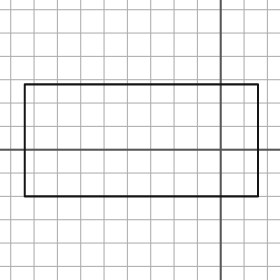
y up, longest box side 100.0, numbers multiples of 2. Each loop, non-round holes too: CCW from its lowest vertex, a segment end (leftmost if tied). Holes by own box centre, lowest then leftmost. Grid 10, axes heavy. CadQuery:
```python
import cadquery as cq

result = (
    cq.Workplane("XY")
    .moveTo(-84.0, -20.0)
    .lineTo(16.0, -20.0)
    .lineTo(16.0, 28.0)
    .lineTo(-84.0, 28.0)
    .close()
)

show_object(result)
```